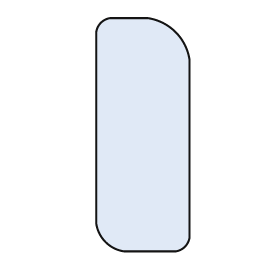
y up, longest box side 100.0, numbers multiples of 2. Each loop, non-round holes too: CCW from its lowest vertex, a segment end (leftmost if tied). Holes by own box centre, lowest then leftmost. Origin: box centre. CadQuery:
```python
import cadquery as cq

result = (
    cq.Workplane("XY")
    .moveTo(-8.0, -50.0)
    .lineTo(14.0, -50.0)
    .threePointArc((18.0, -48.0), (20.0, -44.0))
    .lineTo(20.0, 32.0)
    .threePointArc((14.0, 44.0), (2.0, 50.0))
    .lineTo(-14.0, 50.0)
    .threePointArc((-18.0, 48.0), (-20.0, 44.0))
    .lineTo(-20.0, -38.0)
    .threePointArc((-16.0, -46.0), (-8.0, -50.0))
    .close()
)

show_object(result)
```